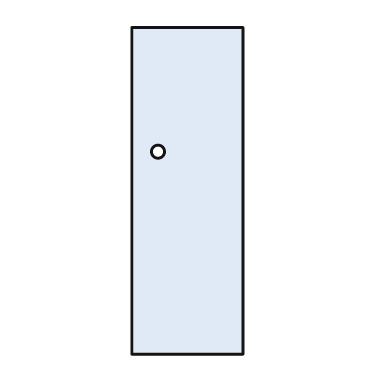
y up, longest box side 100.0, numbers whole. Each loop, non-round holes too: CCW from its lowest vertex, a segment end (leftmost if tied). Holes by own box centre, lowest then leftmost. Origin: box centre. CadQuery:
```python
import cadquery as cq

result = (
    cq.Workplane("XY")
    .moveTo(-17.0, -50.0)
    .lineTo(17.0, -50.0)
    .lineTo(17.0, 50.0)
    .lineTo(-17.0, 50.0)
    .close()
    .moveTo(-9.0, 12.0)
    .circle(2.0)
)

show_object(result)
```